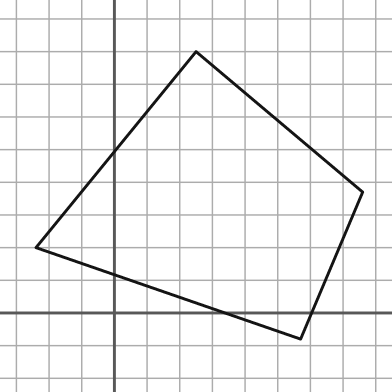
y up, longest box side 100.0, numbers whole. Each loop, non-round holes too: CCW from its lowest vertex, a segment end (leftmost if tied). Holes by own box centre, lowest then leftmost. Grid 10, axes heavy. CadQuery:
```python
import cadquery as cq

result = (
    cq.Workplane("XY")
    .moveTo(57.0, -8.0)
    .lineTo(76.0, 37.0)
    .lineTo(25.0, 80.0)
    .lineTo(-24.0, 20.0)
    .close()
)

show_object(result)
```